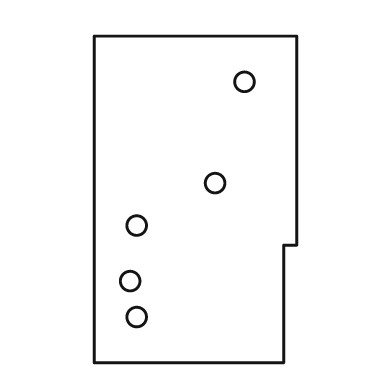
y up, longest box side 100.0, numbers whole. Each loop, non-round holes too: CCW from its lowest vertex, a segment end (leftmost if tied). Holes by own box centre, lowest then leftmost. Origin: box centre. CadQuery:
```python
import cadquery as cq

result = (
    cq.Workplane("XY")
    .moveTo(-31.0, -50.0)
    .lineTo(27.0, -50.0)
    .lineTo(27.0, -14.0)
    .lineTo(31.0, -14.0)
    .lineTo(31.0, 50.0)
    .lineTo(-31.0, 50.0)
    .close()
    .moveTo(-18.0, -36.0)
    .circle(3.0)
    .moveTo(-20.0, -25.0)
    .circle(3.0)
    .moveTo(-18.0, -8.0)
    .circle(3.0)
    .moveTo(6.0, 5.0)
    .circle(3.0)
    .moveTo(15.0, 36.0)
    .circle(3.0)
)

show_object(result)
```